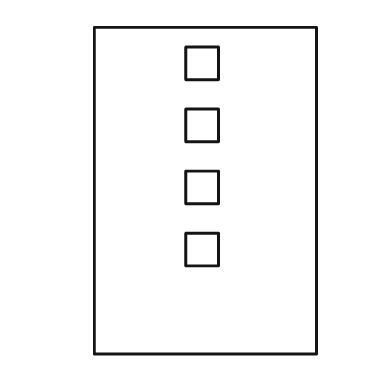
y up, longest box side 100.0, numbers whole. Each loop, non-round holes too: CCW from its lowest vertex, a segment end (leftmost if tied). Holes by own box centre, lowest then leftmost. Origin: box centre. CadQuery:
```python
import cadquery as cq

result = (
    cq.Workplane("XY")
    .moveTo(-34.0, -50.0)
    .lineTo(34.0, -50.0)
    .lineTo(34.0, 50.0)
    .lineTo(-34.0, 50.0)
    .close()
    .moveTo(-6.0, -23.0)
    .lineTo(4.0, -23.0)
    .lineTo(4.0, -13.0)
    .lineTo(-6.0, -13.0)
    .close()
    .moveTo(-6.0, -4.0)
    .lineTo(4.0, -4.0)
    .lineTo(4.0, 6.0)
    .lineTo(-6.0, 6.0)
    .close()
    .moveTo(-6.0, 15.0)
    .lineTo(4.0, 15.0)
    .lineTo(4.0, 25.0)
    .lineTo(-6.0, 25.0)
    .close()
    .moveTo(-6.0, 34.0)
    .lineTo(4.0, 34.0)
    .lineTo(4.0, 44.0)
    .lineTo(-6.0, 44.0)
    .close()
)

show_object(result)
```